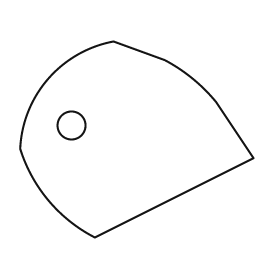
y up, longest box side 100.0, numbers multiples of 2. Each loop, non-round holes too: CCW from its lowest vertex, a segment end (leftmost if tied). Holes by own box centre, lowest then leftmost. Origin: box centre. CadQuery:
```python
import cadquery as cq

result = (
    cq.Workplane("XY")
    .moveTo(-18.0, -42.0)
    .lineTo(50.0, -8.0)
    .lineTo(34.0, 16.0)
    .threePointArc((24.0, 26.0), (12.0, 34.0))
    .lineTo(-10.0, 42.0)
    .threePointArc((-38.0, 26.0), (-50.0, -4.0))
    .threePointArc((-38.0, -26.0), (-18.0, -42.0))
    .close()
    .moveTo(-28.0, 6.0)
    .circle(6.0)
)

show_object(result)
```